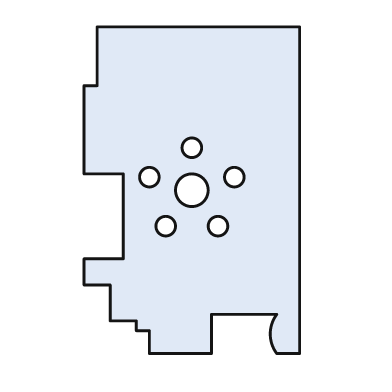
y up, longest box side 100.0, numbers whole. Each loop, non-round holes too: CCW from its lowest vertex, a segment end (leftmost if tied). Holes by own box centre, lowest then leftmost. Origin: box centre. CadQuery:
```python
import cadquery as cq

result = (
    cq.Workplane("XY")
    .moveTo(-13.0, -50.0)
    .lineTo(6.0, -50.0)
    .lineTo(6.0, -38.0)
    .lineTo(26.0, -38.0)
    .threePointArc((24.0, -44.0), (26.0, -50.0))
    .lineTo(33.0, -50.0)
    .lineTo(33.0, 50.0)
    .lineTo(-29.0, 50.0)
    .lineTo(-29.0, 32.0)
    .lineTo(-33.0, 32.0)
    .lineTo(-33.0, 5.0)
    .lineTo(-21.0, 5.0)
    .lineTo(-21.0, -21.0)
    .lineTo(-33.0, -21.0)
    .lineTo(-33.0, -29.0)
    .lineTo(-25.0, -29.0)
    .lineTo(-25.0, -40.0)
    .lineTo(-17.0, -40.0)
    .lineTo(-17.0, -43.0)
    .lineTo(-13.0, -43.0)
    .close()
    .moveTo(-8.0, -11.0)
    .circle(3.0)
    .moveTo(8.0, -11.0)
    .circle(3.0)
    .moveTo(0.0, 0.0)
    .circle(5.0)
    .moveTo(-13.0, 4.0)
    .circle(3.0)
    .moveTo(13.0, 4.0)
    .circle(3.0)
    .moveTo(0.0, 13.0)
    .circle(3.0)
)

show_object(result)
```